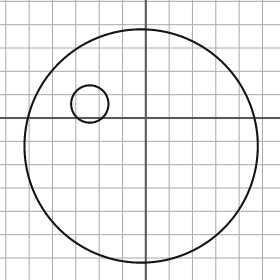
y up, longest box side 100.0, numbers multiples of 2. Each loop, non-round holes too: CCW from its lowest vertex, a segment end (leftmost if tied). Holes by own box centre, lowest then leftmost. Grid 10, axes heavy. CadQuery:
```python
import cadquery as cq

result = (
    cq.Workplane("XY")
    .moveTo(-2.0, -12.0)
    .circle(50.0)
    .moveTo(-24.0, 6.0)
    .circle(8.0)
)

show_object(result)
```